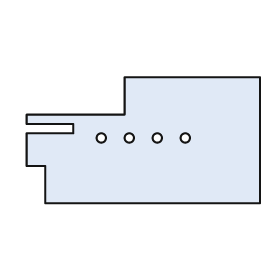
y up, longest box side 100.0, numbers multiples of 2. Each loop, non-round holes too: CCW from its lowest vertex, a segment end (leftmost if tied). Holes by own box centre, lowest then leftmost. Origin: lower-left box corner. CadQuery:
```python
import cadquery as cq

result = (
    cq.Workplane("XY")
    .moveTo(8.0, 0.0)
    .lineTo(100.0, 0.0)
    .lineTo(100.0, 54.0)
    .lineTo(42.0, 54.0)
    .lineTo(42.0, 38.0)
    .lineTo(0.0, 38.0)
    .lineTo(0.0, 34.0)
    .lineTo(20.0, 34.0)
    .lineTo(20.0, 30.0)
    .lineTo(0.0, 30.0)
    .lineTo(0.0, 16.0)
    .lineTo(8.0, 16.0)
    .close()
    .moveTo(32.0, 28.0)
    .circle(2.0)
    .moveTo(44.0, 28.0)
    .circle(2.0)
    .moveTo(56.0, 28.0)
    .circle(2.0)
    .moveTo(68.0, 28.0)
    .circle(2.0)
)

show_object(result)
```